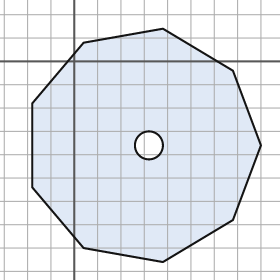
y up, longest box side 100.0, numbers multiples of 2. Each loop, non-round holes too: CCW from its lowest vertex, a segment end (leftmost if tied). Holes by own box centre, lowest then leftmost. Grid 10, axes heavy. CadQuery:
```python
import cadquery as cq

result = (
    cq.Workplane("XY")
    .moveTo(38.0, -86.0)
    .lineTo(68.0, -68.0)
    .lineTo(80.0, -36.0)
    .lineTo(68.0, -4.0)
    .lineTo(38.0, 14.0)
    .lineTo(4.0, 8.0)
    .lineTo(-18.0, -18.0)
    .lineTo(-18.0, -54.0)
    .lineTo(4.0, -80.0)
    .close()
    .moveTo(32.0, -36.0)
    .circle(6.0)
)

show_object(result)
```